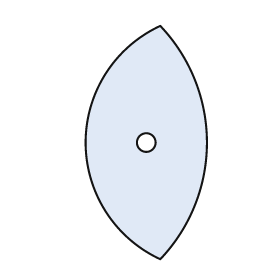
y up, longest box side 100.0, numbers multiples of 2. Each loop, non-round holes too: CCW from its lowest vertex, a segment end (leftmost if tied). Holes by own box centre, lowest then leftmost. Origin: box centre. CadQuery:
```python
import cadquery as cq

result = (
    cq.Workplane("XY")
    .moveTo(6.0, -50.0)
    .threePointArc((26.0, 0.0), (6.0, 50.0))
    .threePointArc((-26.0, 0.0), (6.0, -50.0))
    .close()
    .moveTo(0.0, 0.0)
    .circle(4.0)
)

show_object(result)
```